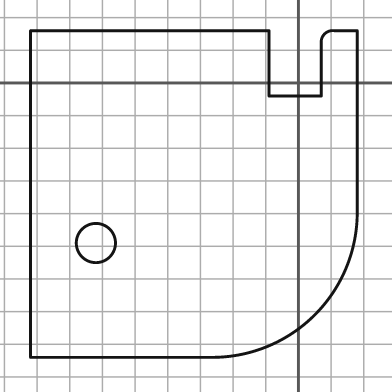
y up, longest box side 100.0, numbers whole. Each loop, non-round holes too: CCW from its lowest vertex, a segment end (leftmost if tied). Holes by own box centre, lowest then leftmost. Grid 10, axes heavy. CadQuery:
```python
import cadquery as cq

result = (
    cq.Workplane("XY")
    .moveTo(-82.0, -84.0)
    .lineTo(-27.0, -84.0)
    .threePointArc((5.0, -71.0), (18.0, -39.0))
    .lineTo(18.0, 16.0)
    .lineTo(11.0, 16.0)
    .threePointArc((8.0, 15.0), (7.0, 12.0))
    .lineTo(7.0, -4.0)
    .lineTo(-9.0, -4.0)
    .lineTo(-9.0, 16.0)
    .lineTo(-82.0, 16.0)
    .close()
    .moveTo(-62.0, -49.0)
    .circle(6.0)
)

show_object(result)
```